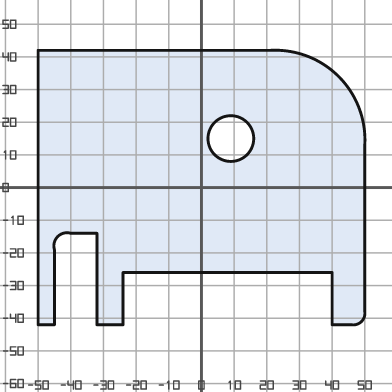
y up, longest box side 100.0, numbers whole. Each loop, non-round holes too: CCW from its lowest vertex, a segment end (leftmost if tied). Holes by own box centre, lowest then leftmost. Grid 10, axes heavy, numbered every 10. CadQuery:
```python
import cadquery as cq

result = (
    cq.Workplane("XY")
    .moveTo(-50.0, -42.0)
    .lineTo(-45.0, -42.0)
    .lineTo(-45.0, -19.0)
    .threePointArc((-44.0, -15.0), (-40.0, -14.0))
    .lineTo(-32.0, -14.0)
    .lineTo(-32.0, -42.0)
    .lineTo(-24.0, -42.0)
    .lineTo(-24.0, -26.0)
    .lineTo(40.0, -26.0)
    .lineTo(40.0, -42.0)
    .lineTo(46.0, -42.0)
    .threePointArc((49.0, -41.0), (50.0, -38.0))
    .lineTo(50.0, 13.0)
    .threePointArc((42.0, 34.0), (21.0, 42.0))
    .lineTo(-50.0, 42.0)
    .close()
    .moveTo(9.0, 15.0)
    .circle(7.0)
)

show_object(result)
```